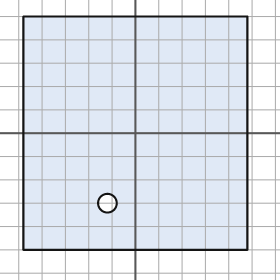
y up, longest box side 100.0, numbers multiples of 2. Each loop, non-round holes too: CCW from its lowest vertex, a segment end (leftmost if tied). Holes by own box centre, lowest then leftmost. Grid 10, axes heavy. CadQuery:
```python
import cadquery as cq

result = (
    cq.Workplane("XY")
    .moveTo(-48.0, -50.0)
    .lineTo(48.0, -50.0)
    .lineTo(48.0, 50.0)
    .lineTo(-48.0, 50.0)
    .close()
    .moveTo(-12.0, -30.0)
    .circle(4.0)
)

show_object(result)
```